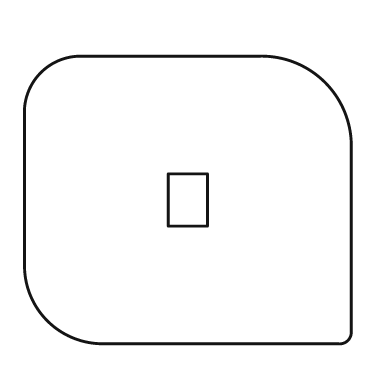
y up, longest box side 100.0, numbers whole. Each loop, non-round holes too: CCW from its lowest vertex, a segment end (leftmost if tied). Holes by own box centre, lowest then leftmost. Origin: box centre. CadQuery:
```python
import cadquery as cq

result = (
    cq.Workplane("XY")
    .moveTo(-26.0, -44.0)
    .lineTo(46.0, -44.0)
    .threePointArc((49.0, -43.0), (50.0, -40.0))
    .lineTo(50.0, 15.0)
    .threePointArc((42.0, 36.0), (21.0, 44.0))
    .lineTo(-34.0, 44.0)
    .threePointArc((-45.0, 39.0), (-50.0, 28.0))
    .lineTo(-50.0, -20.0)
    .threePointArc((-43.0, -37.0), (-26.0, -44.0))
    .close()
    .moveTo(-6.0, -8.0)
    .lineTo(6.0, -8.0)
    .lineTo(6.0, 8.0)
    .lineTo(-6.0, 8.0)
    .close()
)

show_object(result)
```